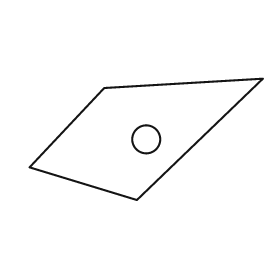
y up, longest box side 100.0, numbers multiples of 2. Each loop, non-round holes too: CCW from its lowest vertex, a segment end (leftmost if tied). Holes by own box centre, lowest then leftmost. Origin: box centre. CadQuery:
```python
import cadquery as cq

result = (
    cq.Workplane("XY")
    .moveTo(-4.0, -26.0)
    .lineTo(50.0, 26.0)
    .lineTo(-18.0, 22.0)
    .lineTo(-50.0, -12.0)
    .close()
    .moveTo(0.0, 0.0)
    .circle(6.0)
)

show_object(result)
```